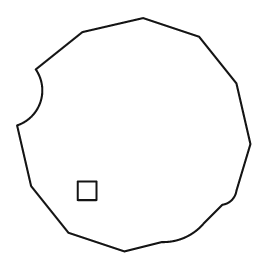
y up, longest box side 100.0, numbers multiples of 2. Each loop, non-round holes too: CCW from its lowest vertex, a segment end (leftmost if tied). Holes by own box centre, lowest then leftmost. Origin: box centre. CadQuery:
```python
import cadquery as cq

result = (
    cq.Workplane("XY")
    .moveTo(-4.0, -50.0)
    .lineTo(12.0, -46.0)
    .threePointArc((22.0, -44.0), (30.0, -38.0))
    .lineTo(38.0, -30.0)
    .threePointArc((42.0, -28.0), (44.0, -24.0))
    .lineTo(50.0, -4.0)
    .lineTo(44.0, 22.0)
    .lineTo(28.0, 42.0)
    .lineTo(4.0, 50.0)
    .lineTo(-22.0, 44.0)
    .lineTo(-42.0, 28.0)
    .threePointArc((-40.0, 14.0), (-50.0, 4.0))
    .lineTo(-44.0, -22.0)
    .lineTo(-28.0, -42.0)
    .close()
    .moveTo(-24.0, -28.0)
    .lineTo(-16.0, -28.0)
    .lineTo(-16.0, -20.0)
    .lineTo(-24.0, -20.0)
    .close()
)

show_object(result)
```